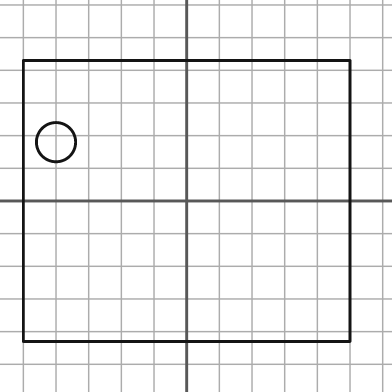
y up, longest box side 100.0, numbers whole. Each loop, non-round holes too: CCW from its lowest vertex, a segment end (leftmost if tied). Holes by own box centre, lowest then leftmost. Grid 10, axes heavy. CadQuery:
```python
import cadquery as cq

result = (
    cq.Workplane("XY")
    .moveTo(-50.0, -43.0)
    .lineTo(50.0, -43.0)
    .lineTo(50.0, 43.0)
    .lineTo(-50.0, 43.0)
    .close()
    .moveTo(-40.0, 18.0)
    .circle(6.0)
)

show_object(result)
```